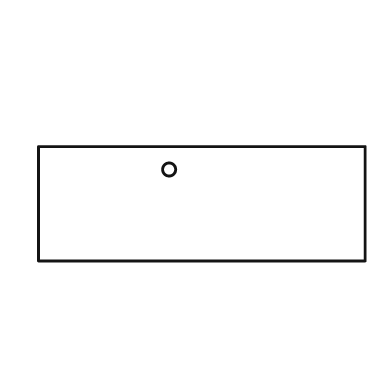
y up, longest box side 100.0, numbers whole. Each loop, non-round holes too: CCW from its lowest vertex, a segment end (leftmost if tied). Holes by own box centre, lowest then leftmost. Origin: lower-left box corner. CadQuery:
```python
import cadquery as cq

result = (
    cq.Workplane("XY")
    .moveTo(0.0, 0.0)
    .lineTo(100.0, 0.0)
    .lineTo(100.0, 35.0)
    .lineTo(0.0, 35.0)
    .close()
    .moveTo(40.0, 28.0)
    .circle(2.0)
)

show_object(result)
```